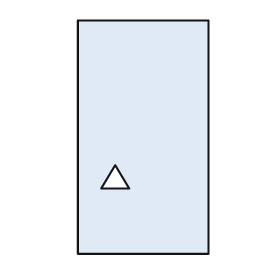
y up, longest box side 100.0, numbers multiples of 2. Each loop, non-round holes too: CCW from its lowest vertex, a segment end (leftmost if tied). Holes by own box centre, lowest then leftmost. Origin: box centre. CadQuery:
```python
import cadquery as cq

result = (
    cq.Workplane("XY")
    .moveTo(-28.0, -50.0)
    .lineTo(28.0, -50.0)
    .lineTo(28.0, 50.0)
    .lineTo(-28.0, 50.0)
    .close()
    .moveTo(-18.0, -22.0)
    .lineTo(-6.0, -22.0)
    .lineTo(-12.0, -12.0)
    .close()
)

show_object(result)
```